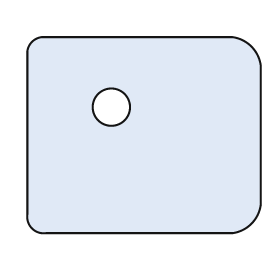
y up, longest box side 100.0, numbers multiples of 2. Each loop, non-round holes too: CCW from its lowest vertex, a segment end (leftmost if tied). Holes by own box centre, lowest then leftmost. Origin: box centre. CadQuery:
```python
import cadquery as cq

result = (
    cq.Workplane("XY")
    .moveTo(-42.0, -42.0)
    .lineTo(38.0, -42.0)
    .threePointArc((46.0, -38.0), (50.0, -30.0))
    .lineTo(50.0, 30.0)
    .threePointArc((46.0, 38.0), (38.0, 42.0))
    .lineTo(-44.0, 42.0)
    .threePointArc((-48.0, 40.0), (-50.0, 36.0))
    .lineTo(-50.0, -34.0)
    .threePointArc((-48.0, -40.0), (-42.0, -42.0))
    .close()
    .moveTo(-14.0, 12.0)
    .circle(8.0)
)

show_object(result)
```